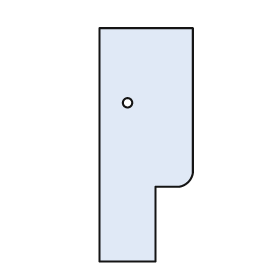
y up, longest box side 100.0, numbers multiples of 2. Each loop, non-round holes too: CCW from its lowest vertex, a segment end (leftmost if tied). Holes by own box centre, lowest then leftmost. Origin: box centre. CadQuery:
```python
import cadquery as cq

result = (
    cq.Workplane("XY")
    .moveTo(-20.0, -50.0)
    .lineTo(4.0, -50.0)
    .lineTo(4.0, -18.0)
    .lineTo(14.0, -18.0)
    .threePointArc((18.0, -16.0), (20.0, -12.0))
    .lineTo(20.0, 50.0)
    .lineTo(-20.0, 50.0)
    .close()
    .moveTo(-8.0, 18.0)
    .circle(2.0)
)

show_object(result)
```